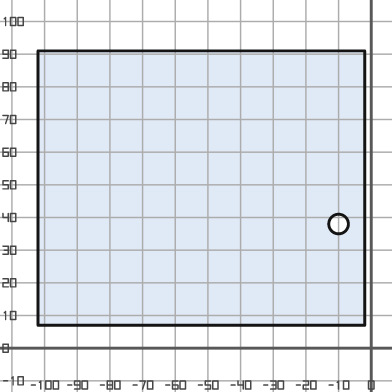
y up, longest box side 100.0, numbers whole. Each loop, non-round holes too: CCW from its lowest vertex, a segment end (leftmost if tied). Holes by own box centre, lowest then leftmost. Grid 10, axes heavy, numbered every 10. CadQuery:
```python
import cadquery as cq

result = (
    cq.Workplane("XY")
    .moveTo(-102.0, 7.0)
    .lineTo(-2.0, 7.0)
    .lineTo(-2.0, 91.0)
    .lineTo(-102.0, 91.0)
    .close()
    .moveTo(-10.0, 38.0)
    .circle(3.0)
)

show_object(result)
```